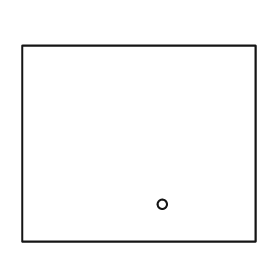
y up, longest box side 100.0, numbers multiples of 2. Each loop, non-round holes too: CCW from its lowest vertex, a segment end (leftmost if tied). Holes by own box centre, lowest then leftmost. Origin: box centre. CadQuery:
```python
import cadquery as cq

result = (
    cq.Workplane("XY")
    .moveTo(-50.0, -42.0)
    .lineTo(50.0, -42.0)
    .lineTo(50.0, 42.0)
    .lineTo(-50.0, 42.0)
    .close()
    .moveTo(10.0, -26.0)
    .circle(2.0)
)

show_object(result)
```